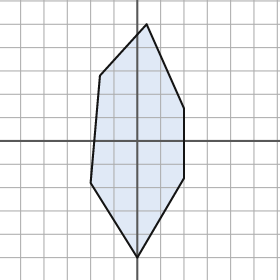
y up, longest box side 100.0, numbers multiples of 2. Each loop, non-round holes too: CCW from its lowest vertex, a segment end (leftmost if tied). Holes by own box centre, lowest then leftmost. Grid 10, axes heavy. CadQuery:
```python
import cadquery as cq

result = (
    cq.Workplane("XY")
    .moveTo(0.0, -50.0)
    .lineTo(20.0, -16.0)
    .lineTo(20.0, 14.0)
    .lineTo(4.0, 50.0)
    .lineTo(-16.0, 28.0)
    .lineTo(-20.0, -18.0)
    .close()
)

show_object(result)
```